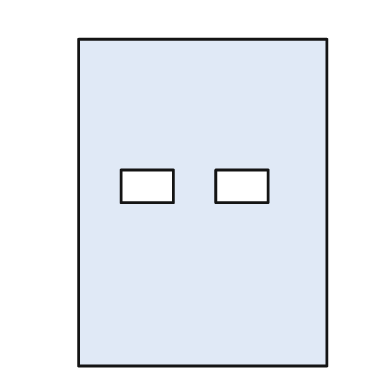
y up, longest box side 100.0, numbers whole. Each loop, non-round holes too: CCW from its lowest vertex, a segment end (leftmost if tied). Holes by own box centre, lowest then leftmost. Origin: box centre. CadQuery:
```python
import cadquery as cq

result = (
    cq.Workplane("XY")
    .moveTo(-38.0, -50.0)
    .lineTo(38.0, -50.0)
    .lineTo(38.0, 50.0)
    .lineTo(-38.0, 50.0)
    .close()
    .moveTo(-25.0, 0.0)
    .lineTo(-9.0, 0.0)
    .lineTo(-9.0, 10.0)
    .lineTo(-25.0, 10.0)
    .close()
    .moveTo(4.0, 0.0)
    .lineTo(20.0, 0.0)
    .lineTo(20.0, 10.0)
    .lineTo(4.0, 10.0)
    .close()
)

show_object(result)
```